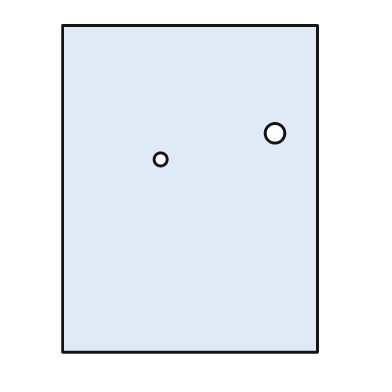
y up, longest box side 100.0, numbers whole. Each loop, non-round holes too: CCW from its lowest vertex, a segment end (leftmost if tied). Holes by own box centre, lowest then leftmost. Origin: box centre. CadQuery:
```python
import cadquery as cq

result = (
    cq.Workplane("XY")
    .moveTo(-39.0, -50.0)
    .lineTo(39.0, -50.0)
    .lineTo(39.0, 50.0)
    .lineTo(-39.0, 50.0)
    .close()
    .moveTo(-9.0, 9.0)
    .circle(2.0)
    .moveTo(26.0, 17.0)
    .circle(3.0)
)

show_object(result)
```